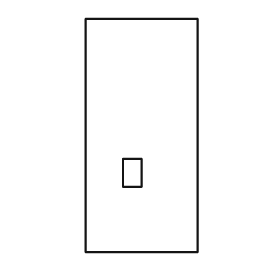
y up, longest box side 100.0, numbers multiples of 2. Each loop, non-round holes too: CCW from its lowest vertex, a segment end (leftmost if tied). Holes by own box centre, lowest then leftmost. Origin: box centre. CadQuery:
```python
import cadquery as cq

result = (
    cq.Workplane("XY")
    .moveTo(-24.0, -50.0)
    .lineTo(24.0, -50.0)
    .lineTo(24.0, 50.0)
    .lineTo(-24.0, 50.0)
    .close()
    .moveTo(-8.0, -22.0)
    .lineTo(0.0, -22.0)
    .lineTo(0.0, -10.0)
    .lineTo(-8.0, -10.0)
    .close()
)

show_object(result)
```